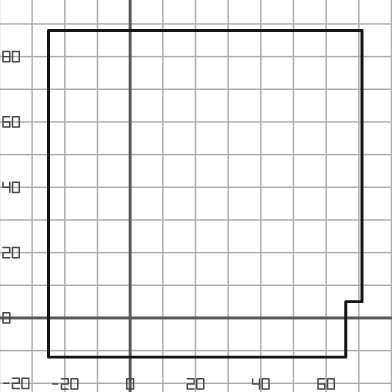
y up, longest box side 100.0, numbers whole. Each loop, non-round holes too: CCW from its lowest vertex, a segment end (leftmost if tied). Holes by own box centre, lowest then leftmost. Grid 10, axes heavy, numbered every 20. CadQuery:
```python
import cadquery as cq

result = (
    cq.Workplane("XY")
    .moveTo(-25.0, -12.0)
    .lineTo(66.0, -12.0)
    .lineTo(66.0, 5.0)
    .lineTo(71.0, 5.0)
    .lineTo(71.0, 88.0)
    .lineTo(-25.0, 88.0)
    .close()
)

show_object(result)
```